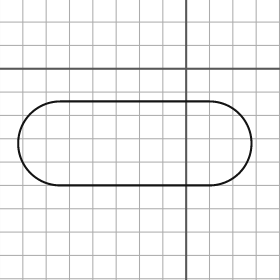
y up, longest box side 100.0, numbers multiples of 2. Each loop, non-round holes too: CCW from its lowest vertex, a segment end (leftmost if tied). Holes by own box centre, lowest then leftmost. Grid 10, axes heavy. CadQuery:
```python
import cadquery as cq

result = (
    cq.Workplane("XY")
    .moveTo(-54.0, -50.0)
    .lineTo(10.0, -50.0)
    .threePointArc((28.0, -32.0), (10.0, -14.0))
    .lineTo(-54.0, -14.0)
    .threePointArc((-72.0, -32.0), (-54.0, -50.0))
    .close()
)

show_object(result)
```